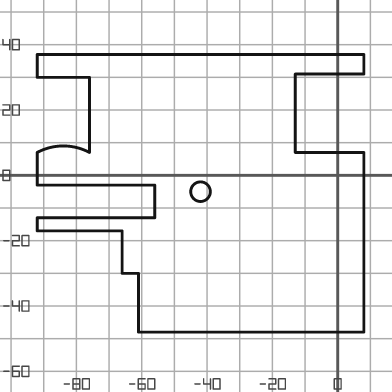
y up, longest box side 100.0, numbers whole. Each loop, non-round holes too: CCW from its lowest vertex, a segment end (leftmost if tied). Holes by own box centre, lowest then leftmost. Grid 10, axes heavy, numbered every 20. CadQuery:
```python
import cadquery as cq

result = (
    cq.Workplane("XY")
    .moveTo(-61.0, -48.0)
    .lineTo(8.0, -48.0)
    .lineTo(8.0, 7.0)
    .lineTo(-13.0, 7.0)
    .lineTo(-13.0, 31.0)
    .lineTo(8.0, 31.0)
    .lineTo(8.0, 37.0)
    .lineTo(-92.0, 37.0)
    .lineTo(-92.0, 30.0)
    .lineTo(-76.0, 30.0)
    .lineTo(-76.0, 7.0)
    .threePointArc((-84.0, 9.0), (-92.0, 7.0))
    .lineTo(-92.0, -3.0)
    .lineTo(-56.0, -3.0)
    .lineTo(-56.0, -13.0)
    .lineTo(-92.0, -13.0)
    .lineTo(-92.0, -17.0)
    .lineTo(-66.0, -17.0)
    .lineTo(-66.0, -30.0)
    .lineTo(-61.0, -30.0)
    .close()
    .moveTo(-42.0, -5.0)
    .circle(3.0)
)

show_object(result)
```